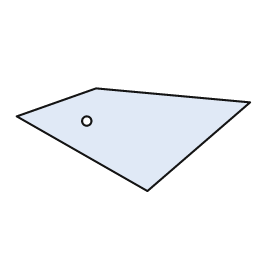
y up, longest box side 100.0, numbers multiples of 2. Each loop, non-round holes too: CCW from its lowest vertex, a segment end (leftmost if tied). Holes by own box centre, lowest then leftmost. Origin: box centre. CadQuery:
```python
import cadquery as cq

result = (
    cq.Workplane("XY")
    .moveTo(6.0, -22.0)
    .lineTo(50.0, 16.0)
    .lineTo(-16.0, 22.0)
    .lineTo(-50.0, 10.0)
    .close()
    .moveTo(-20.0, 8.0)
    .circle(2.0)
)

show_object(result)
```